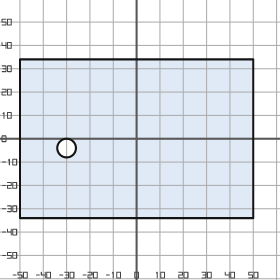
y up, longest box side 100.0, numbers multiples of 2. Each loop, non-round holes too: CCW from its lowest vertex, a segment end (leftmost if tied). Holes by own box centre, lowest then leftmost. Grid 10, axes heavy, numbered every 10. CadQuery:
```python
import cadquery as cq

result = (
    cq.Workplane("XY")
    .moveTo(-50.0, -34.0)
    .lineTo(50.0, -34.0)
    .lineTo(50.0, 34.0)
    .lineTo(-50.0, 34.0)
    .close()
    .moveTo(-30.0, -4.0)
    .circle(4.0)
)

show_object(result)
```